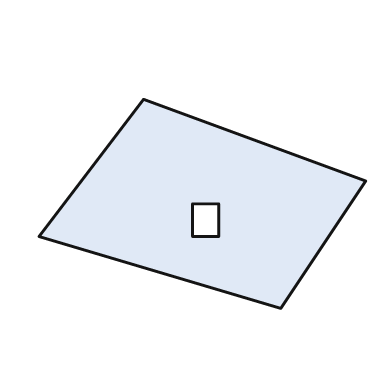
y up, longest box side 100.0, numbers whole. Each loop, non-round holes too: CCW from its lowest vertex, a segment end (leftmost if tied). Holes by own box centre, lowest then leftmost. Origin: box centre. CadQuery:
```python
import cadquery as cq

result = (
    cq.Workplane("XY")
    .moveTo(24.0, -32.0)
    .lineTo(50.0, 7.0)
    .lineTo(-18.0, 32.0)
    .lineTo(-50.0, -10.0)
    .close()
    .moveTo(-3.0, -10.0)
    .lineTo(5.0, -10.0)
    .lineTo(5.0, 0.0)
    .lineTo(-3.0, 0.0)
    .close()
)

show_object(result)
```